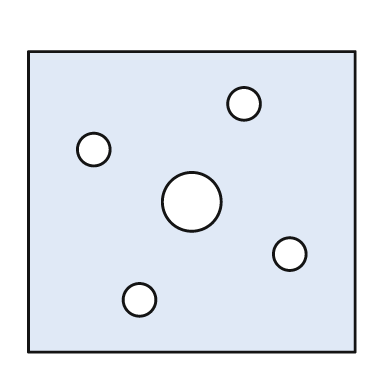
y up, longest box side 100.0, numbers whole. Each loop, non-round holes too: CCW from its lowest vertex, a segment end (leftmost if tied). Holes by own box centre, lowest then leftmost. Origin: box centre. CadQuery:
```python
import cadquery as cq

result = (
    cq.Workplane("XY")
    .moveTo(-50.0, -46.0)
    .lineTo(50.0, -46.0)
    .lineTo(50.0, 46.0)
    .lineTo(-50.0, 46.0)
    .close()
    .moveTo(-16.0, -30.0)
    .circle(5.0)
    .moveTo(30.0, -16.0)
    .circle(5.0)
    .moveTo(0.0, 0.0)
    .circle(9.0)
    .moveTo(-30.0, 16.0)
    .circle(5.0)
    .moveTo(16.0, 30.0)
    .circle(5.0)
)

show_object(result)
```